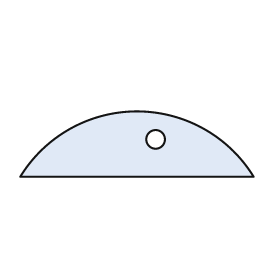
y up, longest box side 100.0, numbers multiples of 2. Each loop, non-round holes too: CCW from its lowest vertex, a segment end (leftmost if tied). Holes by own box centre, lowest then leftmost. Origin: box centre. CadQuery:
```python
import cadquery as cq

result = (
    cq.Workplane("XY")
    .moveTo(-50.0, -14.0)
    .lineTo(50.0, -14.0)
    .threePointArc((0.0, 14.0), (-50.0, -14.0))
    .close()
    .moveTo(8.0, 2.0)
    .circle(4.0)
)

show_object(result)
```